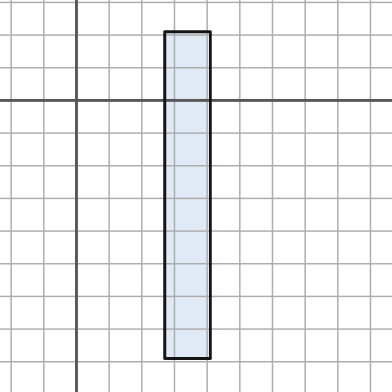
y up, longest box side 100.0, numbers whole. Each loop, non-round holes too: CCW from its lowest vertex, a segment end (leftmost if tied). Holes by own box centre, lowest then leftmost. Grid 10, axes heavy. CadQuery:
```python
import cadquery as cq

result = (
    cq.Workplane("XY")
    .moveTo(27.0, -79.0)
    .lineTo(41.0, -79.0)
    .lineTo(41.0, 21.0)
    .lineTo(27.0, 21.0)
    .close()
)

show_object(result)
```